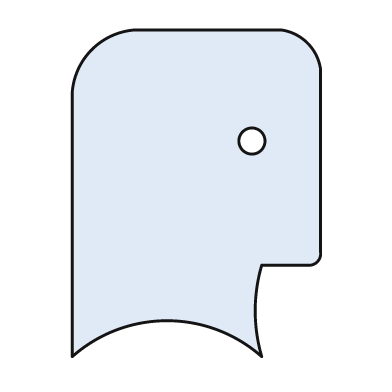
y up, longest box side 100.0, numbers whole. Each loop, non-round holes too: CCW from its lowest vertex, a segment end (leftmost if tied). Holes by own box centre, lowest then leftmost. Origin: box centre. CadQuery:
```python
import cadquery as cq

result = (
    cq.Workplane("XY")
    .moveTo(-38.0, -50.0)
    .threePointArc((-9.0, -39.0), (20.0, -50.0))
    .threePointArc((18.0, -36.0), (20.0, -22.0))
    .lineTo(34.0, -22.0)
    .threePointArc((37.0, -21.0), (38.0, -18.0))
    .lineTo(38.0, 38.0)
    .threePointArc((34.0, 46.0), (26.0, 50.0))
    .lineTo(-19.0, 50.0)
    .threePointArc((-32.0, 44.0), (-38.0, 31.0))
    .close()
    .moveTo(17.0, 16.0)
    .circle(4.0)
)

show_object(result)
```